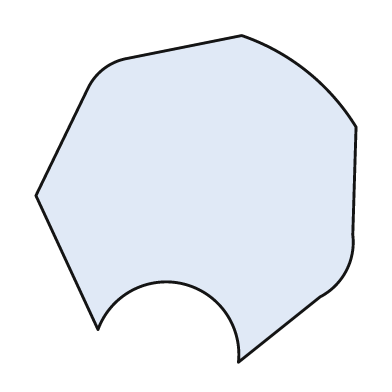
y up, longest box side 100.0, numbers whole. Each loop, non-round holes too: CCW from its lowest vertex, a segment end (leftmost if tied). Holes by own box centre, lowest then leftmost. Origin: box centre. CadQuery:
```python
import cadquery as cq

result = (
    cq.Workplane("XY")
    .moveTo(13.0, -50.0)
    .lineTo(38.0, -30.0)
    .threePointArc((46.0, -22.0), (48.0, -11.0))
    .lineTo(49.0, 22.0)
    .threePointArc((34.0, 39.0), (14.0, 50.0))
    .lineTo(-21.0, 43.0)
    .threePointArc((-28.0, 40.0), (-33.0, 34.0))
    .lineTo(-49.0, 1.0)
    .lineTo(-30.0, -40.0)
    .threePointArc((-4.0, -26.0), (13.0, -50.0))
    .close()
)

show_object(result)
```